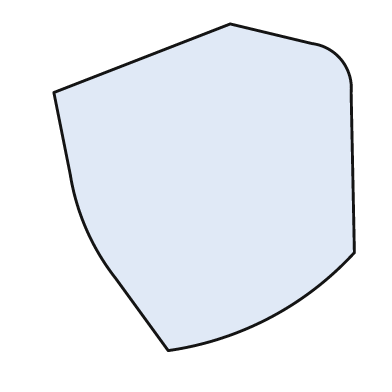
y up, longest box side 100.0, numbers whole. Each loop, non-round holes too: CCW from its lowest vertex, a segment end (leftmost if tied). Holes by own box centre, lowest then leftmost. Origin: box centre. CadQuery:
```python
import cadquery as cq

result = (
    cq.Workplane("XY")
    .moveTo(-11.0, -50.0)
    .threePointArc((20.0, -40.0), (46.0, -20.0))
    .lineTo(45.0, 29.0)
    .threePointArc((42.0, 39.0), (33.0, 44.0))
    .lineTo(8.0, 50.0)
    .lineTo(-46.0, 29.0)
    .lineTo(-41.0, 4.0)
    .threePointArc((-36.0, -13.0), (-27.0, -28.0))
    .close()
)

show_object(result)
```